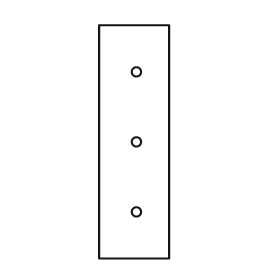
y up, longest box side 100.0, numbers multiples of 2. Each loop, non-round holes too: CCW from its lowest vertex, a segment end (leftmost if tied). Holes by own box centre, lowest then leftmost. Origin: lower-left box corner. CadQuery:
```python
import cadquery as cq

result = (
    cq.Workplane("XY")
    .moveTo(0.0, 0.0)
    .lineTo(30.0, 0.0)
    .lineTo(30.0, 100.0)
    .lineTo(0.0, 100.0)
    .close()
    .moveTo(16.0, 20.0)
    .circle(2.0)
    .moveTo(16.0, 50.0)
    .circle(2.0)
    .moveTo(16.0, 80.0)
    .circle(2.0)
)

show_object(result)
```